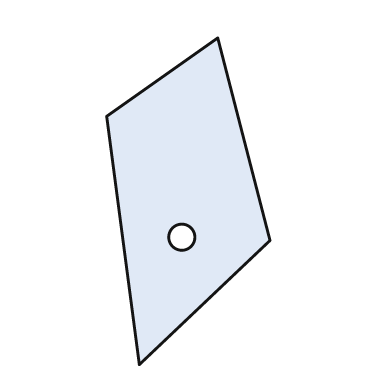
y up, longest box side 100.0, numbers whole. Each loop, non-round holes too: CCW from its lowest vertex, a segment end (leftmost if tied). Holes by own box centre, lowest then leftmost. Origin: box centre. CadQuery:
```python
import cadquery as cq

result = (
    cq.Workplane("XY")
    .moveTo(-15.0, -50.0)
    .lineTo(25.0, -12.0)
    .lineTo(9.0, 50.0)
    .lineTo(-25.0, 26.0)
    .close()
    .moveTo(-2.0, -11.0)
    .circle(4.0)
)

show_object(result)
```